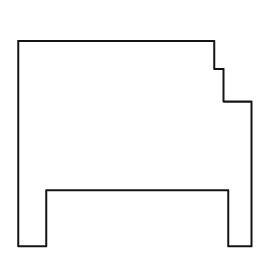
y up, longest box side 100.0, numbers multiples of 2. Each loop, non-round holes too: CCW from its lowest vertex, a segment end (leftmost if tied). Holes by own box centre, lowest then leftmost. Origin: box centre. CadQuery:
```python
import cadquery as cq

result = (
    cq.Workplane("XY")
    .moveTo(-50.0, -44.0)
    .lineTo(-38.0, -44.0)
    .lineTo(-38.0, -20.0)
    .lineTo(40.0, -20.0)
    .lineTo(40.0, -44.0)
    .lineTo(50.0, -44.0)
    .lineTo(50.0, 18.0)
    .lineTo(38.0, 18.0)
    .lineTo(38.0, 32.0)
    .lineTo(34.0, 32.0)
    .lineTo(34.0, 44.0)
    .lineTo(-50.0, 44.0)
    .close()
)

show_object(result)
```